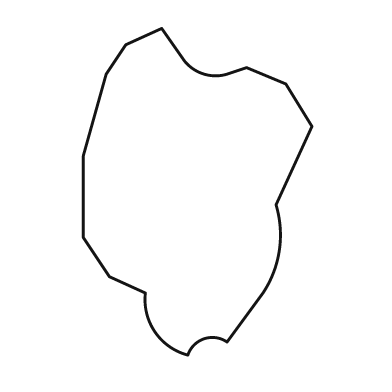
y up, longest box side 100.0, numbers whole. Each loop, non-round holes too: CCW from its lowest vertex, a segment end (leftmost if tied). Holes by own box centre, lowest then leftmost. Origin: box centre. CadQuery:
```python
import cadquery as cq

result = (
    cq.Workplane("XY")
    .moveTo(-3.0, -50.0)
    .threePointArc((2.0, -45.0), (9.0, -46.0))
    .lineTo(20.0, -31.0)
    .threePointArc((25.0, -18.0), (24.0, -4.0))
    .lineTo(35.0, 20.0)
    .lineTo(27.0, 33.0)
    .lineTo(15.0, 38.0)
    .lineTo(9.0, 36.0)
    .threePointArc((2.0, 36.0), (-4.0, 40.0))
    .lineTo(-11.0, 50.0)
    .lineTo(-22.0, 45.0)
    .lineTo(-28.0, 36.0)
    .lineTo(-35.0, 11.0)
    .lineTo(-35.0, -14.0)
    .lineTo(-27.0, -26.0)
    .lineTo(-16.0, -31.0)
    .threePointArc((-13.0, -43.0), (-3.0, -50.0))
    .close()
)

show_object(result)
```